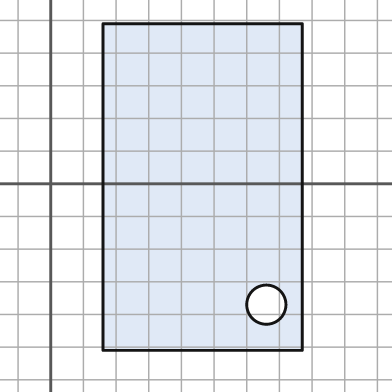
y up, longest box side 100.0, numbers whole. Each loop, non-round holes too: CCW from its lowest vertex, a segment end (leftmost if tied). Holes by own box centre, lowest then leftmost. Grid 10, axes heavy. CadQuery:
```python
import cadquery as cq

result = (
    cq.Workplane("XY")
    .moveTo(16.0, -51.0)
    .lineTo(77.0, -51.0)
    .lineTo(77.0, 49.0)
    .lineTo(16.0, 49.0)
    .close()
    .moveTo(66.0, -37.0)
    .circle(6.0)
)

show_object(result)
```